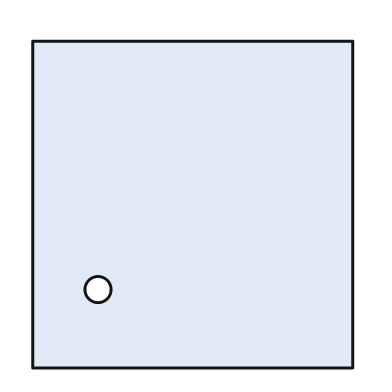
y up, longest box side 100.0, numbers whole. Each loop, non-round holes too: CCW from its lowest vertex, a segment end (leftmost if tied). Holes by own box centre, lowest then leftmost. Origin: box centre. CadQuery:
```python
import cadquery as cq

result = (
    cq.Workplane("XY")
    .moveTo(-49.0, -50.0)
    .lineTo(49.0, -50.0)
    .lineTo(49.0, 50.0)
    .lineTo(-49.0, 50.0)
    .close()
    .moveTo(-29.0, -26.0)
    .circle(4.0)
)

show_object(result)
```